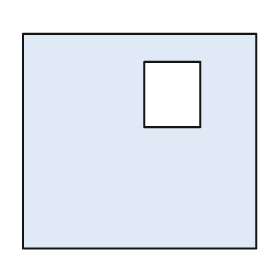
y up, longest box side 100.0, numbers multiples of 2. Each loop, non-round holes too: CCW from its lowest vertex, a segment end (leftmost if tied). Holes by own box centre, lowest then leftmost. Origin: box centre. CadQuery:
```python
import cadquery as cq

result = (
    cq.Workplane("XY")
    .moveTo(-50.0, -46.0)
    .lineTo(50.0, -46.0)
    .lineTo(50.0, 46.0)
    .lineTo(-50.0, 46.0)
    .close()
    .moveTo(2.0, 6.0)
    .lineTo(26.0, 6.0)
    .lineTo(26.0, 34.0)
    .lineTo(2.0, 34.0)
    .close()
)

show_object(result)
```